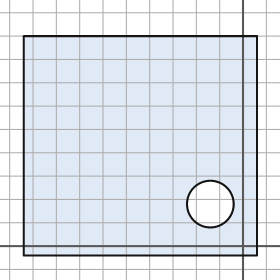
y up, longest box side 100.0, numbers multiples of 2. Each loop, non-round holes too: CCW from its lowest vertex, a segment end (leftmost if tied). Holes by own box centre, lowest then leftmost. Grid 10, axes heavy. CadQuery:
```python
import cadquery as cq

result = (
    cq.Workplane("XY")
    .moveTo(-94.0, -4.0)
    .lineTo(6.0, -4.0)
    .lineTo(6.0, 90.0)
    .lineTo(-94.0, 90.0)
    .close()
    .moveTo(-14.0, 18.0)
    .circle(10.0)
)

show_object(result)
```